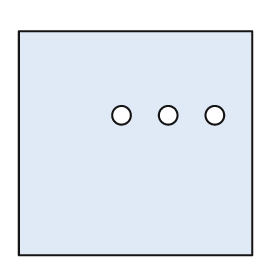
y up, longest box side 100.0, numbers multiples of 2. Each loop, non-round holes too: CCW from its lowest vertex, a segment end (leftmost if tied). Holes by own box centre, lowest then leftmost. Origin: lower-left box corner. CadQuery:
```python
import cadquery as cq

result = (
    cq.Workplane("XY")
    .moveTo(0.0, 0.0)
    .lineTo(100.0, 0.0)
    .lineTo(100.0, 96.0)
    .lineTo(0.0, 96.0)
    .close()
    .moveTo(44.0, 60.0)
    .circle(4.0)
    .moveTo(64.0, 60.0)
    .circle(4.0)
    .moveTo(84.0, 60.0)
    .circle(4.0)
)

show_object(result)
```